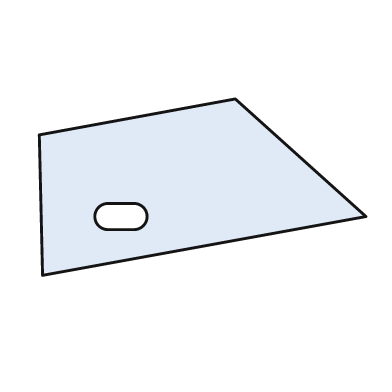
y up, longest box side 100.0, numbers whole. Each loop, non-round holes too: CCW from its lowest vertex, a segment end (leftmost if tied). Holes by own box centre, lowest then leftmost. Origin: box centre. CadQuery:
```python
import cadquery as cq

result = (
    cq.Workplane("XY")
    .moveTo(-49.0, -27.0)
    .lineTo(50.0, -9.0)
    .lineTo(10.0, 27.0)
    .lineTo(-50.0, 16.0)
    .close()
    .moveTo(-29.0, -13.0)
    .lineTo(-21.0, -13.0)
    .threePointArc((-17.0, -9.0), (-21.0, -5.0))
    .lineTo(-29.0, -5.0)
    .threePointArc((-33.0, -9.0), (-29.0, -13.0))
    .close()
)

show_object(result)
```